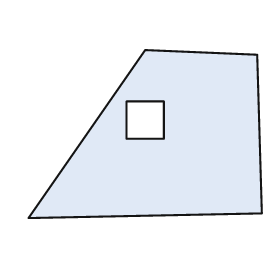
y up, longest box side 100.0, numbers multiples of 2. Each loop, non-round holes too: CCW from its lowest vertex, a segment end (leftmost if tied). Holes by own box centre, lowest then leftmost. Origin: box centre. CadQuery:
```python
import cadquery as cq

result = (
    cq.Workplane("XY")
    .moveTo(-50.0, -36.0)
    .lineTo(50.0, -34.0)
    .lineTo(48.0, 34.0)
    .lineTo(0.0, 36.0)
    .close()
    .moveTo(-8.0, -2.0)
    .lineTo(8.0, -2.0)
    .lineTo(8.0, 14.0)
    .lineTo(-8.0, 14.0)
    .close()
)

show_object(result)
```